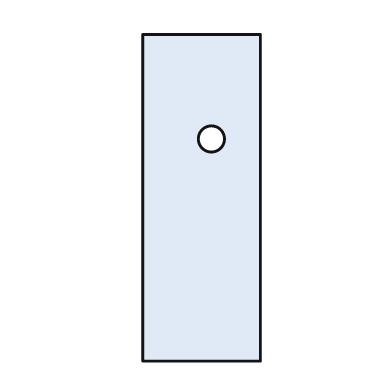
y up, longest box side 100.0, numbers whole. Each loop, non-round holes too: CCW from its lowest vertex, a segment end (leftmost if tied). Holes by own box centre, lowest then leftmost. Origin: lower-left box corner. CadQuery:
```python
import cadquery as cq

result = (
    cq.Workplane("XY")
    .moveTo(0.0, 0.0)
    .lineTo(36.0, 0.0)
    .lineTo(36.0, 100.0)
    .lineTo(0.0, 100.0)
    .close()
    .moveTo(21.0, 68.0)
    .circle(4.0)
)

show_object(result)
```